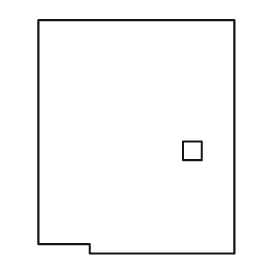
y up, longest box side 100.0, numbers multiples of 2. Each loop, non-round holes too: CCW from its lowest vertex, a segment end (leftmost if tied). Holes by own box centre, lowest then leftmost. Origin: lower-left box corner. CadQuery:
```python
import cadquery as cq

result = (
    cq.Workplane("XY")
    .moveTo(22.0, 0.0)
    .lineTo(84.0, 0.0)
    .lineTo(84.0, 100.0)
    .lineTo(0.0, 100.0)
    .lineTo(0.0, 4.0)
    .lineTo(22.0, 4.0)
    .close()
    .moveTo(62.0, 40.0)
    .lineTo(70.0, 40.0)
    .lineTo(70.0, 48.0)
    .lineTo(62.0, 48.0)
    .close()
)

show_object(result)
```